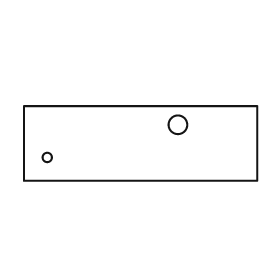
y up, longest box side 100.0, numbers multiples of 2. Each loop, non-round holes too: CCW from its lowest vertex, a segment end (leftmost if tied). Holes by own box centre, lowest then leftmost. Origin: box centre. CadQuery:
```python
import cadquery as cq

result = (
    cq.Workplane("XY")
    .moveTo(-50.0, -16.0)
    .lineTo(50.0, -16.0)
    .lineTo(50.0, 16.0)
    .lineTo(-50.0, 16.0)
    .close()
    .moveTo(-40.0, -6.0)
    .circle(2.0)
    .moveTo(16.0, 8.0)
    .circle(4.0)
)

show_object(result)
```